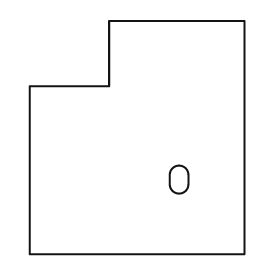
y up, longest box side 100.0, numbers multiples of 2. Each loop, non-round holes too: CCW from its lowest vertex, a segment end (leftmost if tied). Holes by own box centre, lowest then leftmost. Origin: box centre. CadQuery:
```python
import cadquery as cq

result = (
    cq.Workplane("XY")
    .moveTo(-46.0, -50.0)
    .lineTo(46.0, -50.0)
    .lineTo(46.0, 50.0)
    .lineTo(-12.0, 50.0)
    .lineTo(-12.0, 22.0)
    .lineTo(-46.0, 22.0)
    .close()
    .moveTo(14.0, -20.0)
    .threePointArc((18.0, -24.0), (22.0, -20.0))
    .lineTo(22.0, -16.0)
    .threePointArc((18.0, -12.0), (14.0, -16.0))
    .close()
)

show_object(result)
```